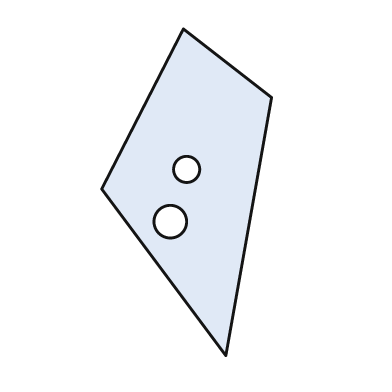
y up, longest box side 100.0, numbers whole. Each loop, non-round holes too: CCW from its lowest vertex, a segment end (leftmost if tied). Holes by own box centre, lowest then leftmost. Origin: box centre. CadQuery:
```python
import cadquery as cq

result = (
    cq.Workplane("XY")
    .moveTo(12.0, -50.0)
    .lineTo(26.0, 29.0)
    .lineTo(-1.0, 50.0)
    .lineTo(-26.0, 1.0)
    .close()
    .moveTo(-5.0, -9.0)
    .circle(5.0)
    .moveTo(0.0, 7.0)
    .circle(4.0)
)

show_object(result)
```